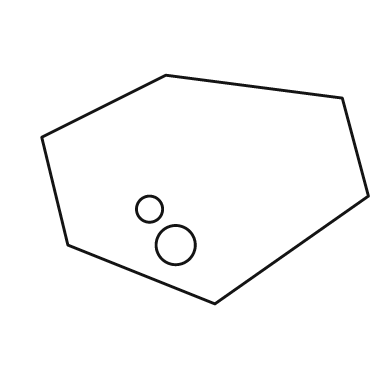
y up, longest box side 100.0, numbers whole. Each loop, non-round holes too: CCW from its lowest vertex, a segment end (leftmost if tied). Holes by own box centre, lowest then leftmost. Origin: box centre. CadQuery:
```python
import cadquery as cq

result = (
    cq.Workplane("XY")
    .moveTo(3.0, -35.0)
    .lineTo(50.0, -2.0)
    .lineTo(42.0, 28.0)
    .lineTo(-12.0, 35.0)
    .lineTo(-50.0, 16.0)
    .lineTo(-42.0, -17.0)
    .close()
    .moveTo(-9.0, -17.0)
    .circle(6.0)
    .moveTo(-17.0, -6.0)
    .circle(4.0)
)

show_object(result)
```